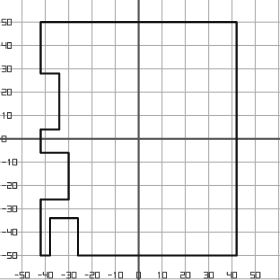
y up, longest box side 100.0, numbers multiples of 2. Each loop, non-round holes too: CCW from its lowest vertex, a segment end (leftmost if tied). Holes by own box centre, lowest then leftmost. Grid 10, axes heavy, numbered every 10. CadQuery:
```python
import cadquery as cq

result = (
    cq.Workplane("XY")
    .moveTo(-42.0, -50.0)
    .lineTo(-38.0, -50.0)
    .lineTo(-38.0, -34.0)
    .lineTo(-26.0, -34.0)
    .lineTo(-26.0, -50.0)
    .lineTo(42.0, -50.0)
    .lineTo(42.0, 50.0)
    .lineTo(-42.0, 50.0)
    .lineTo(-42.0, 28.0)
    .lineTo(-34.0, 28.0)
    .lineTo(-34.0, 4.0)
    .lineTo(-42.0, 4.0)
    .lineTo(-42.0, -6.0)
    .lineTo(-30.0, -6.0)
    .lineTo(-30.0, -26.0)
    .lineTo(-42.0, -26.0)
    .close()
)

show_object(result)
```